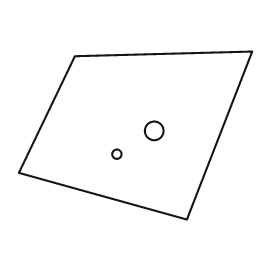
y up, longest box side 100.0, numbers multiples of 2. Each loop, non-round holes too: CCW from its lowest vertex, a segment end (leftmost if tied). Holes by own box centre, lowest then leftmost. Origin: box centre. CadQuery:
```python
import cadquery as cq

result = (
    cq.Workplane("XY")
    .moveTo(22.0, -36.0)
    .lineTo(50.0, 36.0)
    .lineTo(-26.0, 34.0)
    .lineTo(-50.0, -16.0)
    .close()
    .moveTo(-8.0, -8.0)
    .circle(2.0)
    .moveTo(8.0, 2.0)
    .circle(4.0)
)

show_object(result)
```